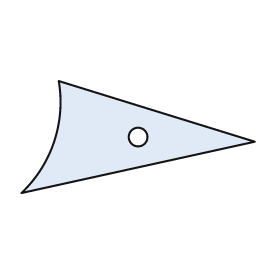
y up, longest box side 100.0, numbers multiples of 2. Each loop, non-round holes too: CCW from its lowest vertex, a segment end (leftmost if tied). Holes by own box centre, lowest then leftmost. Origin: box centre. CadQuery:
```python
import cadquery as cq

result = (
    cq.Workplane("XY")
    .moveTo(-50.0, -24.0)
    .lineTo(50.0, -2.0)
    .lineTo(-34.0, 24.0)
    .threePointArc((-36.0, -2.0), (-50.0, -24.0))
    .close()
    .moveTo(0.0, 0.0)
    .circle(4.0)
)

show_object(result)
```